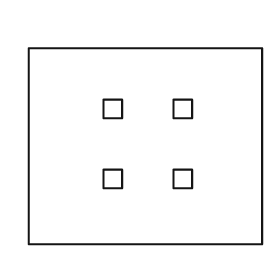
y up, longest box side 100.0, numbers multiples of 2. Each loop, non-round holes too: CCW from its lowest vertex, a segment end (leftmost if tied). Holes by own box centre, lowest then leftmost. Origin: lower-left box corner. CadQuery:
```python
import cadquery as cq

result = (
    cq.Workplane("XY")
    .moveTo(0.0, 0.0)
    .lineTo(100.0, 0.0)
    .lineTo(100.0, 84.0)
    .lineTo(0.0, 84.0)
    .close()
    .moveTo(32.0, 24.0)
    .lineTo(40.0, 24.0)
    .lineTo(40.0, 32.0)
    .lineTo(32.0, 32.0)
    .close()
    .moveTo(62.0, 24.0)
    .lineTo(70.0, 24.0)
    .lineTo(70.0, 32.0)
    .lineTo(62.0, 32.0)
    .close()
    .moveTo(32.0, 54.0)
    .lineTo(40.0, 54.0)
    .lineTo(40.0, 62.0)
    .lineTo(32.0, 62.0)
    .close()
    .moveTo(62.0, 54.0)
    .lineTo(70.0, 54.0)
    .lineTo(70.0, 62.0)
    .lineTo(62.0, 62.0)
    .close()
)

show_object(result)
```